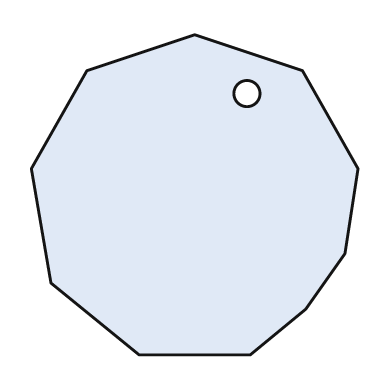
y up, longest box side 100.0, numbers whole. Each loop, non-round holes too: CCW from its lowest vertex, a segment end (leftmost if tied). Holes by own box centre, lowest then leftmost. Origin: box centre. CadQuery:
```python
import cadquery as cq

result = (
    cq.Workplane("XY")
    .moveTo(-17.0, -49.0)
    .lineTo(17.0, -49.0)
    .lineTo(34.0, -35.0)
    .lineTo(46.0, -18.0)
    .lineTo(50.0, 8.0)
    .lineTo(33.0, 38.0)
    .lineTo(0.0, 49.0)
    .lineTo(-33.0, 38.0)
    .lineTo(-50.0, 8.0)
    .lineTo(-44.0, -27.0)
    .close()
    .moveTo(16.0, 31.0)
    .circle(4.0)
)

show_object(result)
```